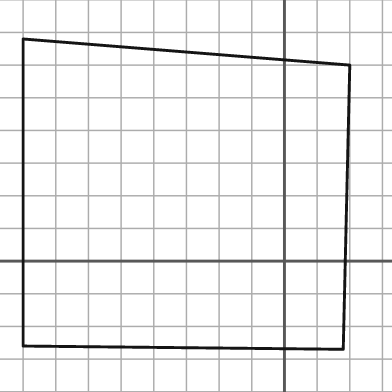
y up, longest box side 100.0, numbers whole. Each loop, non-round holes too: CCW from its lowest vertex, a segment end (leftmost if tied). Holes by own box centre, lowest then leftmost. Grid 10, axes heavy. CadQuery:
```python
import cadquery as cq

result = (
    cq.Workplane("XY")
    .moveTo(18.0, -27.0)
    .lineTo(20.0, 60.0)
    .lineTo(-80.0, 68.0)
    .lineTo(-80.0, -26.0)
    .close()
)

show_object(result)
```